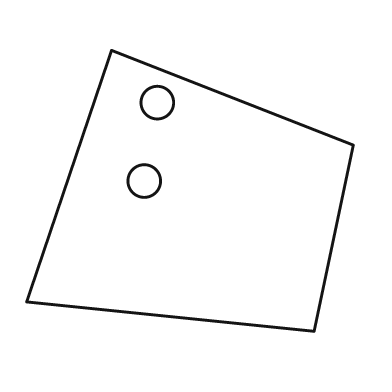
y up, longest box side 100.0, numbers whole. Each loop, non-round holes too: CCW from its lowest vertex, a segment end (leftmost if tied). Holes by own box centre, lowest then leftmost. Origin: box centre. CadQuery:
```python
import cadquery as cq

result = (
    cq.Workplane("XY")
    .moveTo(38.0, -43.0)
    .lineTo(50.0, 14.0)
    .lineTo(-24.0, 43.0)
    .lineTo(-50.0, -34.0)
    .close()
    .moveTo(-14.0, 3.0)
    .circle(5.0)
    .moveTo(-10.0, 27.0)
    .circle(5.0)
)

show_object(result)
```